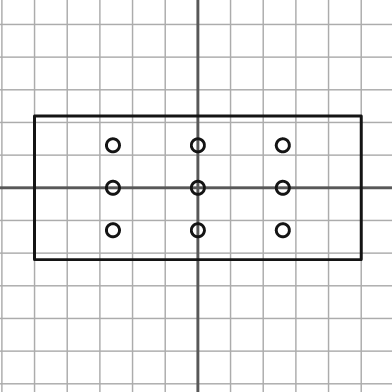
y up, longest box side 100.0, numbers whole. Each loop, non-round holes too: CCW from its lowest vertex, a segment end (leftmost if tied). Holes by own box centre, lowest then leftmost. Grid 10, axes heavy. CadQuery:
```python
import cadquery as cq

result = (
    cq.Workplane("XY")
    .moveTo(-50.0, -22.0)
    .lineTo(50.0, -22.0)
    .lineTo(50.0, 22.0)
    .lineTo(-50.0, 22.0)
    .close()
    .moveTo(-26.0, -13.0)
    .circle(2.0)
    .moveTo(0.0, -13.0)
    .circle(2.0)
    .moveTo(26.0, -13.0)
    .circle(2.0)
    .moveTo(-26.0, 0.0)
    .circle(2.0)
    .moveTo(0.0, 0.0)
    .circle(2.0)
    .moveTo(26.0, 0.0)
    .circle(2.0)
    .moveTo(-26.0, 13.0)
    .circle(2.0)
    .moveTo(0.0, 13.0)
    .circle(2.0)
    .moveTo(26.0, 13.0)
    .circle(2.0)
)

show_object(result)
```